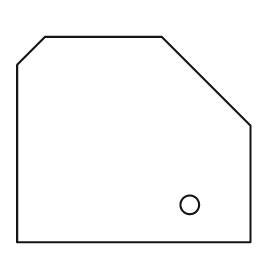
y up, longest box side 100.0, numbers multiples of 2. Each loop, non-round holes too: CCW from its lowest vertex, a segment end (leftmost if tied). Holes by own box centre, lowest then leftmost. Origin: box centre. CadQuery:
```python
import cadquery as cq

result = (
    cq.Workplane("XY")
    .moveTo(-50.0, -44.0)
    .lineTo(50.0, -44.0)
    .lineTo(50.0, 6.0)
    .lineTo(12.0, 44.0)
    .lineTo(-38.0, 44.0)
    .lineTo(-50.0, 32.0)
    .close()
    .moveTo(24.0, -28.0)
    .circle(4.0)
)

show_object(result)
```